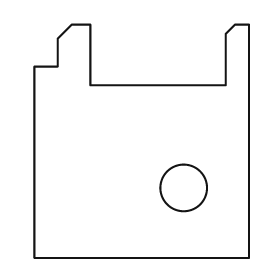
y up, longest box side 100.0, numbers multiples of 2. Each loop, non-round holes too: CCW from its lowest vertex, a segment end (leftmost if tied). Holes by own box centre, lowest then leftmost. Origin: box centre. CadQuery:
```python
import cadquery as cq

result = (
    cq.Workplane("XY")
    .moveTo(-46.0, -50.0)
    .lineTo(46.0, -50.0)
    .lineTo(46.0, 50.0)
    .lineTo(40.0, 50.0)
    .lineTo(36.0, 46.0)
    .lineTo(36.0, 24.0)
    .lineTo(-22.0, 24.0)
    .lineTo(-22.0, 50.0)
    .lineTo(-30.0, 50.0)
    .lineTo(-36.0, 44.0)
    .lineTo(-36.0, 32.0)
    .lineTo(-46.0, 32.0)
    .close()
    .moveTo(18.0, -20.0)
    .circle(10.0)
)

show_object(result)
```